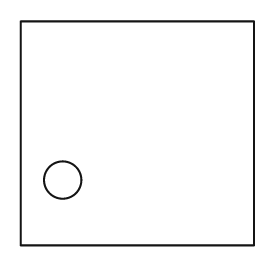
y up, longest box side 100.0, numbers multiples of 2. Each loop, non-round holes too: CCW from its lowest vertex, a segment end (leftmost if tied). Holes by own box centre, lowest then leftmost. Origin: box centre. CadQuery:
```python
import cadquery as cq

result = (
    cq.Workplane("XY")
    .moveTo(-50.0, -48.0)
    .lineTo(50.0, -48.0)
    .lineTo(50.0, 48.0)
    .lineTo(-50.0, 48.0)
    .close()
    .moveTo(-32.0, -20.0)
    .circle(8.0)
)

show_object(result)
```